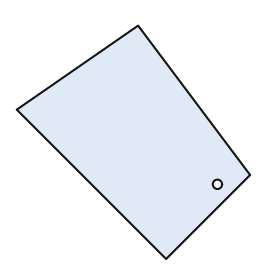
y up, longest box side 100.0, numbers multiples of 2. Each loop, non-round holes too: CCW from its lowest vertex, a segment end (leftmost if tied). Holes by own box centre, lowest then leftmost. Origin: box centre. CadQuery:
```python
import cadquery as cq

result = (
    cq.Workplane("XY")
    .moveTo(14.0, -50.0)
    .lineTo(50.0, -14.0)
    .lineTo(2.0, 50.0)
    .lineTo(-50.0, 14.0)
    .close()
    .moveTo(36.0, -18.0)
    .circle(2.0)
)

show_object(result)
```